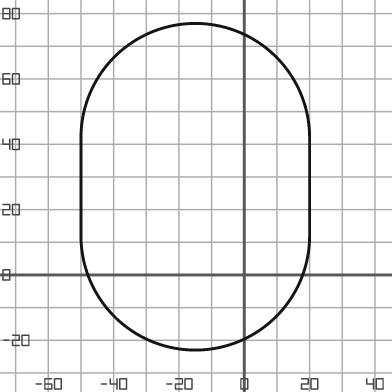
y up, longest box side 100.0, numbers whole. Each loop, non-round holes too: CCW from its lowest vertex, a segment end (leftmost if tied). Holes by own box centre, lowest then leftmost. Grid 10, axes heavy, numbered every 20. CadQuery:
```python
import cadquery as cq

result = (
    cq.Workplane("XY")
    .moveTo(-50.0, 12.0)
    .threePointArc((-15.0, -23.0), (20.0, 12.0))
    .lineTo(20.0, 42.0)
    .threePointArc((-15.0, 77.0), (-50.0, 42.0))
    .close()
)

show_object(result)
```